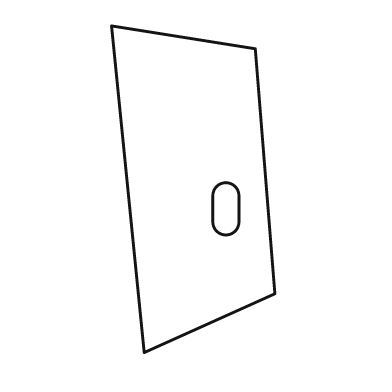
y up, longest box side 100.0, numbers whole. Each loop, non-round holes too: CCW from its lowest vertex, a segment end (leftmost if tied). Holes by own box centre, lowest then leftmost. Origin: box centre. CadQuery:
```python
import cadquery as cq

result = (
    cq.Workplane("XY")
    .moveTo(-15.0, -50.0)
    .lineTo(25.0, -32.0)
    .lineTo(19.0, 43.0)
    .lineTo(-25.0, 50.0)
    .close()
    .moveTo(6.0, -10.0)
    .threePointArc((10.0, -14.0), (14.0, -10.0))
    .lineTo(14.0, -2.0)
    .threePointArc((10.0, 2.0), (6.0, -2.0))
    .close()
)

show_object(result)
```